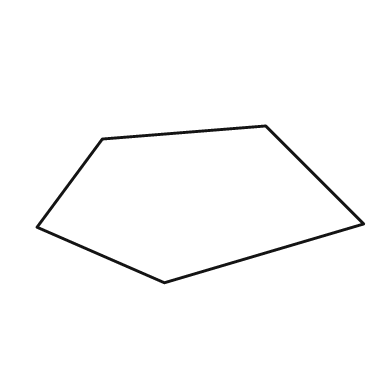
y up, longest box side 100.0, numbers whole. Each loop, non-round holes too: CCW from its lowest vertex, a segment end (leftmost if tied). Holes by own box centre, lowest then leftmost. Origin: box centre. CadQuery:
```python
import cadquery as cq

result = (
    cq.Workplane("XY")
    .moveTo(-11.0, -24.0)
    .lineTo(50.0, -6.0)
    .lineTo(20.0, 24.0)
    .lineTo(-30.0, 20.0)
    .lineTo(-50.0, -7.0)
    .close()
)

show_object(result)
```